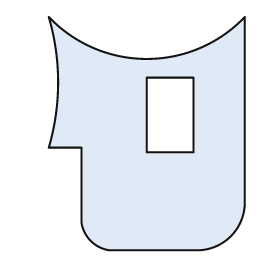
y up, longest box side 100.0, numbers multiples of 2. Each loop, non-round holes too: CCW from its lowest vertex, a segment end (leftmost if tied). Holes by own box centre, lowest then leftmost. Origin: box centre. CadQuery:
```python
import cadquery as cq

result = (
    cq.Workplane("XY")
    .moveTo(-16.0, -50.0)
    .lineTo(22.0, -50.0)
    .threePointArc((36.0, -44.0), (42.0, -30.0))
    .lineTo(42.0, 50.0)
    .threePointArc((0.0, 32.0), (-42.0, 50.0))
    .threePointArc((-38.0, 22.0), (-42.0, -6.0))
    .lineTo(-28.0, -6.0)
    .lineTo(-28.0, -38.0)
    .threePointArc((-24.0, -46.0), (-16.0, -50.0))
    .close()
    .moveTo(0.0, -8.0)
    .lineTo(20.0, -8.0)
    .lineTo(20.0, 24.0)
    .lineTo(0.0, 24.0)
    .close()
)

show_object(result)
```